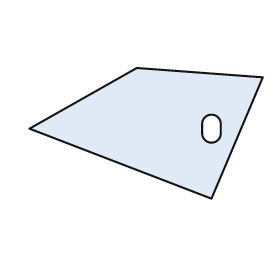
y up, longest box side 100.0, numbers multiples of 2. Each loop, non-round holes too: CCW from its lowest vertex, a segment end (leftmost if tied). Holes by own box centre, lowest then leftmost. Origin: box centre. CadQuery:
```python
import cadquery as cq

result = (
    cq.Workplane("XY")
    .moveTo(28.0, -28.0)
    .lineTo(50.0, 24.0)
    .lineTo(-4.0, 28.0)
    .lineTo(-50.0, 2.0)
    .close()
    .moveTo(24.0, 0.0)
    .threePointArc((28.0, -4.0), (32.0, 0.0))
    .lineTo(32.0, 4.0)
    .threePointArc((28.0, 8.0), (24.0, 4.0))
    .close()
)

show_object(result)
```